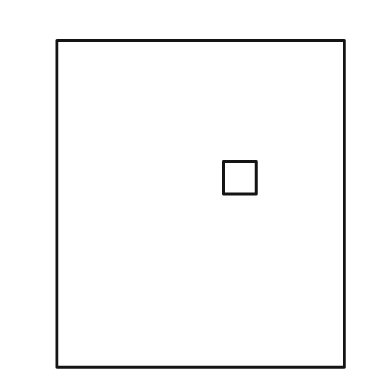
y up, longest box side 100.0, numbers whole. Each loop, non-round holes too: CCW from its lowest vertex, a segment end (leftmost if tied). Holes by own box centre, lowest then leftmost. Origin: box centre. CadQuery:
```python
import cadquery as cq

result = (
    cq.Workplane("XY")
    .moveTo(-44.0, -50.0)
    .lineTo(44.0, -50.0)
    .lineTo(44.0, 50.0)
    .lineTo(-44.0, 50.0)
    .close()
    .moveTo(7.0, 3.0)
    .lineTo(17.0, 3.0)
    .lineTo(17.0, 13.0)
    .lineTo(7.0, 13.0)
    .close()
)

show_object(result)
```